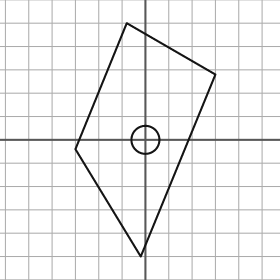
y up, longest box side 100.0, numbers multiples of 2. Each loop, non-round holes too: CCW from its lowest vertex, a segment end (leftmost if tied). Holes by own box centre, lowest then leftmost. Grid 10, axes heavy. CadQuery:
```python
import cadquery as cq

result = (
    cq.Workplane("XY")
    .moveTo(-2.0, -50.0)
    .lineTo(30.0, 28.0)
    .lineTo(-8.0, 50.0)
    .lineTo(-30.0, -4.0)
    .close()
    .moveTo(0.0, 0.0)
    .circle(6.0)
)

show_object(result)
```